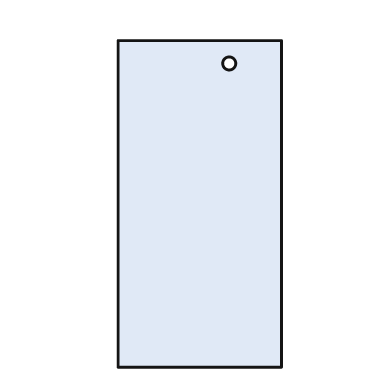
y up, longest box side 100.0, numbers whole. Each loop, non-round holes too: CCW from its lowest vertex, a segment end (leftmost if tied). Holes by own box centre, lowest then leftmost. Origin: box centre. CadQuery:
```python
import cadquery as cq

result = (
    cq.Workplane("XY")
    .moveTo(-25.0, -50.0)
    .lineTo(25.0, -50.0)
    .lineTo(25.0, 50.0)
    .lineTo(-25.0, 50.0)
    .close()
    .moveTo(9.0, 43.0)
    .circle(2.0)
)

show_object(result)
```